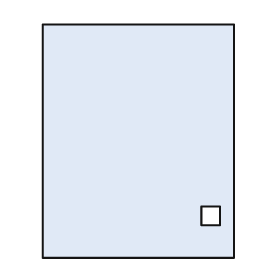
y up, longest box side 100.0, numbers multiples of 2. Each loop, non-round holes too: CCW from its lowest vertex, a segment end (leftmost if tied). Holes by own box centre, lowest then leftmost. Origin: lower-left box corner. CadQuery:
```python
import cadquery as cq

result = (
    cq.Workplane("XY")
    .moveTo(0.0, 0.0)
    .lineTo(82.0, 0.0)
    .lineTo(82.0, 100.0)
    .lineTo(0.0, 100.0)
    .close()
    .moveTo(68.0, 14.0)
    .lineTo(76.0, 14.0)
    .lineTo(76.0, 22.0)
    .lineTo(68.0, 22.0)
    .close()
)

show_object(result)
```